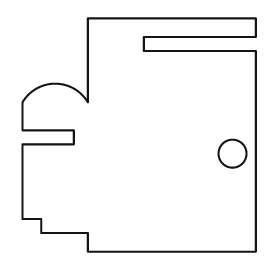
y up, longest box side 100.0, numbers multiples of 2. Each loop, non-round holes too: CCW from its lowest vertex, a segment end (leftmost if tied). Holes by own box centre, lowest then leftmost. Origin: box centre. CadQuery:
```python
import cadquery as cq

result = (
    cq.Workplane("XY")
    .moveTo(-22.0, -50.0)
    .lineTo(50.0, -50.0)
    .lineTo(50.0, 36.0)
    .lineTo(2.0, 36.0)
    .lineTo(2.0, 42.0)
    .lineTo(50.0, 42.0)
    .lineTo(50.0, 50.0)
    .lineTo(-22.0, 50.0)
    .lineTo(-22.0, 14.0)
    .threePointArc((-36.0, 22.0), (-50.0, 14.0))
    .lineTo(-50.0, 2.0)
    .lineTo(-28.0, 2.0)
    .lineTo(-28.0, -4.0)
    .lineTo(-50.0, -4.0)
    .lineTo(-50.0, -36.0)
    .lineTo(-42.0, -36.0)
    .lineTo(-42.0, -42.0)
    .lineTo(-22.0, -42.0)
    .close()
    .moveTo(40.0, -8.0)
    .circle(6.0)
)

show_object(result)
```